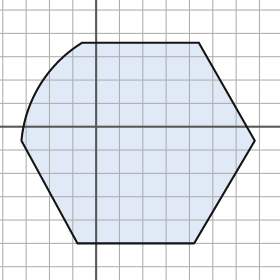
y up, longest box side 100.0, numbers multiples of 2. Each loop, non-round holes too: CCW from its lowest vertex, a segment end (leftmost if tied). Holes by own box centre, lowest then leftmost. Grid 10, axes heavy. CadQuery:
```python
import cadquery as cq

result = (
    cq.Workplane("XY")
    .moveTo(-8.0, -50.0)
    .lineTo(42.0, -50.0)
    .lineTo(68.0, -6.0)
    .lineTo(44.0, 36.0)
    .lineTo(-6.0, 36.0)
    .threePointArc((-24.0, 18.0), (-32.0, -6.0))
    .close()
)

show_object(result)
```